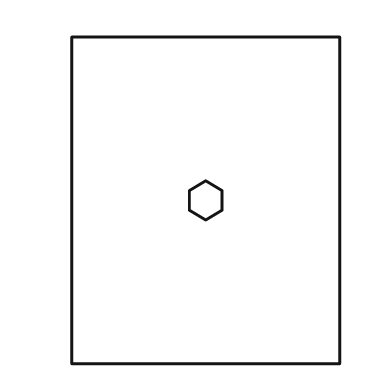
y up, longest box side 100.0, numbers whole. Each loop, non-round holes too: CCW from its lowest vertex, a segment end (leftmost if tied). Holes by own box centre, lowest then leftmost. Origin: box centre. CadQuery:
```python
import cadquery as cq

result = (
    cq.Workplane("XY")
    .moveTo(-41.0, -50.0)
    .lineTo(41.0, -50.0)
    .lineTo(41.0, 50.0)
    .lineTo(-41.0, 50.0)
    .close()
    .moveTo(0.0, -6.0)
    .lineTo(5.0, -3.0)
    .lineTo(5.0, 3.0)
    .lineTo(0.0, 6.0)
    .lineTo(-5.0, 3.0)
    .lineTo(-5.0, -3.0)
    .close()
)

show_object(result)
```